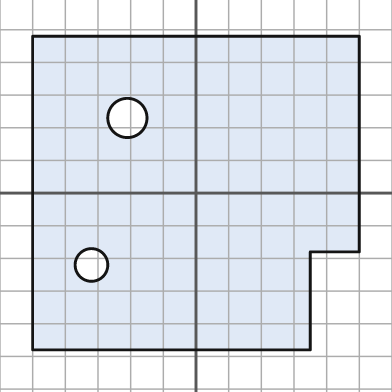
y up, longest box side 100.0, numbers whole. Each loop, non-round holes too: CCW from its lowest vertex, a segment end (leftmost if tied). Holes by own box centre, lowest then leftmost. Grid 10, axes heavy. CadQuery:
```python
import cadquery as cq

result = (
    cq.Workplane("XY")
    .moveTo(-50.0, -48.0)
    .lineTo(35.0, -48.0)
    .lineTo(35.0, -18.0)
    .lineTo(50.0, -18.0)
    .lineTo(50.0, 48.0)
    .lineTo(-50.0, 48.0)
    .close()
    .moveTo(-32.0, -22.0)
    .circle(5.0)
    .moveTo(-21.0, 23.0)
    .circle(6.0)
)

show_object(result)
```